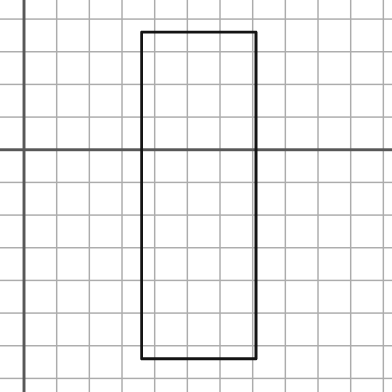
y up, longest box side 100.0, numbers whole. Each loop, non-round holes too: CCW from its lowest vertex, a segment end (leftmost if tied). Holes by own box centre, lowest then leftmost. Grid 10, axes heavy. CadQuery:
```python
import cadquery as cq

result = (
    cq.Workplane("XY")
    .moveTo(36.0, -64.0)
    .lineTo(71.0, -64.0)
    .lineTo(71.0, 36.0)
    .lineTo(36.0, 36.0)
    .close()
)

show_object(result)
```